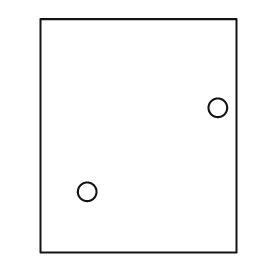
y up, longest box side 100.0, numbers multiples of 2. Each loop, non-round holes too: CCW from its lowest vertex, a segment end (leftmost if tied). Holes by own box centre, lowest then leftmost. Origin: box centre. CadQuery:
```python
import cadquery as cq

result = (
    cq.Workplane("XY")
    .moveTo(-42.0, -50.0)
    .lineTo(42.0, -50.0)
    .lineTo(42.0, 50.0)
    .lineTo(-42.0, 50.0)
    .close()
    .moveTo(-22.0, -24.0)
    .circle(4.0)
    .moveTo(34.0, 12.0)
    .circle(4.0)
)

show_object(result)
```